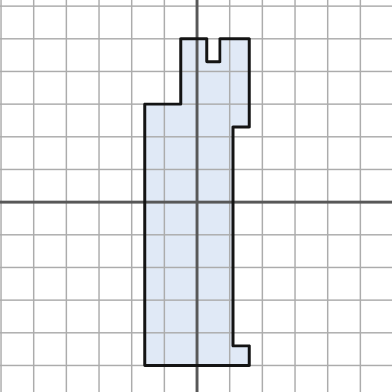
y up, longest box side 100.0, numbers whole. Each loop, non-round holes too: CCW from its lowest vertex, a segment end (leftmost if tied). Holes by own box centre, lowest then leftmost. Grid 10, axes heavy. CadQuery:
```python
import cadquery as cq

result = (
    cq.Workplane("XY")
    .moveTo(-16.0, -50.0)
    .lineTo(16.0, -50.0)
    .lineTo(16.0, -44.0)
    .lineTo(11.0, -44.0)
    .lineTo(11.0, 23.0)
    .lineTo(16.0, 23.0)
    .lineTo(16.0, 50.0)
    .lineTo(7.0, 50.0)
    .lineTo(7.0, 43.0)
    .lineTo(3.0, 43.0)
    .lineTo(3.0, 50.0)
    .lineTo(-5.0, 50.0)
    .lineTo(-5.0, 30.0)
    .lineTo(-16.0, 30.0)
    .close()
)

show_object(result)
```